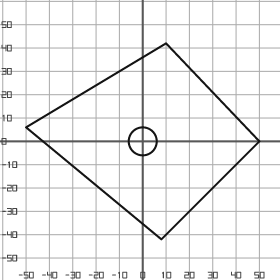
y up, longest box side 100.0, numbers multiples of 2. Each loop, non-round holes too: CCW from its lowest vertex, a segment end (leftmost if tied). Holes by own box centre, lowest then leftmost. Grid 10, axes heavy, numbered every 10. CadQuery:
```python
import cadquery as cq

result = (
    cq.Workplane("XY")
    .moveTo(8.0, -42.0)
    .lineTo(50.0, 0.0)
    .lineTo(10.0, 42.0)
    .lineTo(-50.0, 6.0)
    .close()
    .moveTo(0.0, 0.0)
    .circle(6.0)
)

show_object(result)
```